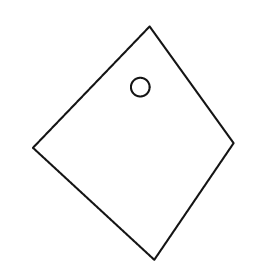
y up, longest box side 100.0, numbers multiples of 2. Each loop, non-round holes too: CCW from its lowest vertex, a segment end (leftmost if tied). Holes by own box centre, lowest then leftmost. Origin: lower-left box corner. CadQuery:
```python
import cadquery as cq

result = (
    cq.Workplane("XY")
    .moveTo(52.0, 0.0)
    .lineTo(86.0, 50.0)
    .lineTo(50.0, 100.0)
    .lineTo(0.0, 48.0)
    .close()
    .moveTo(46.0, 74.0)
    .circle(4.0)
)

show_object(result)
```